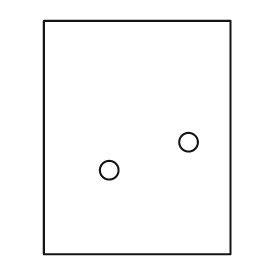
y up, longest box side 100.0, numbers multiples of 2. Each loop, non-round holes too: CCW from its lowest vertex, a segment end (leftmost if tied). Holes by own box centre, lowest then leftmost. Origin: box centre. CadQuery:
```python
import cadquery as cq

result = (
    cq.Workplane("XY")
    .moveTo(-40.0, -50.0)
    .lineTo(40.0, -50.0)
    .lineTo(40.0, 50.0)
    .lineTo(-40.0, 50.0)
    .close()
    .moveTo(-12.0, -14.0)
    .circle(4.0)
    .moveTo(22.0, -2.0)
    .circle(4.0)
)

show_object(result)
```